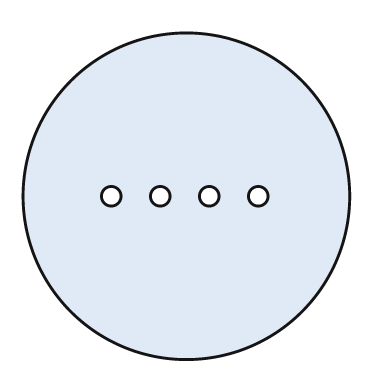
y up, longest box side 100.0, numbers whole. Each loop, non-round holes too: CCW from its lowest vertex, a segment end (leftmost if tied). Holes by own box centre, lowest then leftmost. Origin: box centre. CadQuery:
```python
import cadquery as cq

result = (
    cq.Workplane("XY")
    .moveTo(0.0, 0.0)
    .circle(50.0)
    .moveTo(-23.0, 0.0)
    .circle(3.0)
    .moveTo(-8.0, 0.0)
    .circle(3.0)
    .moveTo(7.0, 0.0)
    .circle(3.0)
    .moveTo(22.0, 0.0)
    .circle(3.0)
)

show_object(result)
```